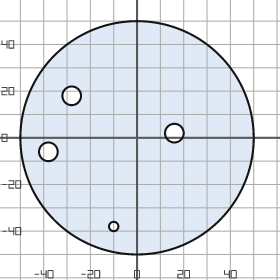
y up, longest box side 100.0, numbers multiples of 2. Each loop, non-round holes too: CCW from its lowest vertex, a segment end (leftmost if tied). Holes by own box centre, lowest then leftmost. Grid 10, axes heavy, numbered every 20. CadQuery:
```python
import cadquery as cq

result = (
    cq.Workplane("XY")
    .moveTo(0.0, 0.0)
    .circle(50.0)
    .moveTo(-10.0, -38.0)
    .circle(2.0)
    .moveTo(-38.0, -6.0)
    .circle(4.0)
    .moveTo(16.0, 2.0)
    .circle(4.0)
    .moveTo(-28.0, 18.0)
    .circle(4.0)
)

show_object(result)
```